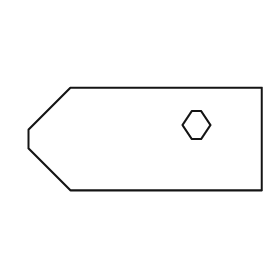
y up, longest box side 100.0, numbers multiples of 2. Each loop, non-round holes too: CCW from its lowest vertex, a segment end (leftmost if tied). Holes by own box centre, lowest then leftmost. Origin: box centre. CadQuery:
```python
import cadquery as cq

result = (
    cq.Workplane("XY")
    .moveTo(-32.0, -22.0)
    .lineTo(50.0, -22.0)
    .lineTo(50.0, 22.0)
    .lineTo(-32.0, 22.0)
    .lineTo(-50.0, 4.0)
    .lineTo(-50.0, -4.0)
    .close()
    .moveTo(20.0, 0.0)
    .lineTo(24.0, 0.0)
    .lineTo(28.0, 6.0)
    .lineTo(24.0, 12.0)
    .lineTo(20.0, 12.0)
    .lineTo(16.0, 6.0)
    .close()
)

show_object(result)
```